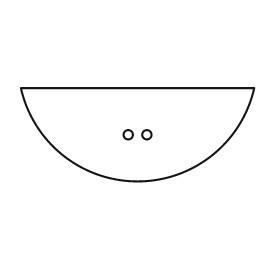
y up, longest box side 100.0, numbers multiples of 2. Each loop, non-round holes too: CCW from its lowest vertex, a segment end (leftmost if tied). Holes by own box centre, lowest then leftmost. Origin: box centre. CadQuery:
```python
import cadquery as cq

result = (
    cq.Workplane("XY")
    .moveTo(-50.0, 20.0)
    .threePointArc((0.0, -20.0), (50.0, 20.0))
    .close()
    .moveTo(-4.0, 0.0)
    .circle(2.0)
    .moveTo(4.0, 0.0)
    .circle(2.0)
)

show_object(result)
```